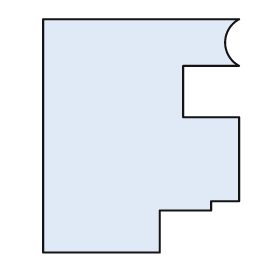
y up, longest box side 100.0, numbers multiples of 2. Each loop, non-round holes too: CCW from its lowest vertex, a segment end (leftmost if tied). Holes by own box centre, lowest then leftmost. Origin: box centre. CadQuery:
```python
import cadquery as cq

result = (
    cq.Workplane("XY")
    .moveTo(-42.0, -50.0)
    .lineTo(8.0, -50.0)
    .lineTo(8.0, -32.0)
    .lineTo(30.0, -32.0)
    .lineTo(30.0, -28.0)
    .lineTo(42.0, -28.0)
    .lineTo(42.0, 8.0)
    .lineTo(18.0, 8.0)
    .lineTo(18.0, 30.0)
    .lineTo(42.0, 30.0)
    .threePointArc((36.0, 40.0), (42.0, 50.0))
    .lineTo(-42.0, 50.0)
    .close()
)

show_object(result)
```